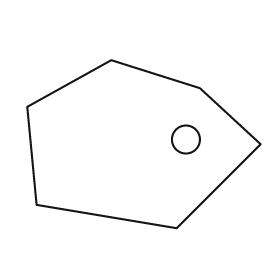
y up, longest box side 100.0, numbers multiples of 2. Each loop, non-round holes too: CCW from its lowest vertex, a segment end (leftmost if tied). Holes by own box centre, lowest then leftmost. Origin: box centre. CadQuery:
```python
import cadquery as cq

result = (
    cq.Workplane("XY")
    .moveTo(14.0, -36.0)
    .lineTo(50.0, 0.0)
    .lineTo(24.0, 24.0)
    .lineTo(-14.0, 36.0)
    .lineTo(-50.0, 16.0)
    .lineTo(-46.0, -26.0)
    .close()
    .moveTo(18.0, 2.0)
    .circle(6.0)
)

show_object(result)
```